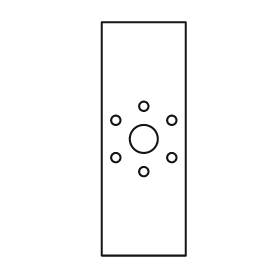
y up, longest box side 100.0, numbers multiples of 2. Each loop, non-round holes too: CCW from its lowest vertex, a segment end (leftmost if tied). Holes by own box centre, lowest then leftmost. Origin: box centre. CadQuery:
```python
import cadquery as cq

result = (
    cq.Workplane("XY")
    .moveTo(-18.0, -50.0)
    .lineTo(18.0, -50.0)
    .lineTo(18.0, 50.0)
    .lineTo(-18.0, 50.0)
    .close()
    .moveTo(0.0, -14.0)
    .circle(2.0)
    .moveTo(-12.0, -8.0)
    .circle(2.0)
    .moveTo(12.0, -8.0)
    .circle(2.0)
    .moveTo(0.0, 0.0)
    .circle(6.0)
    .moveTo(-12.0, 8.0)
    .circle(2.0)
    .moveTo(12.0, 8.0)
    .circle(2.0)
    .moveTo(0.0, 14.0)
    .circle(2.0)
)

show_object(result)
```